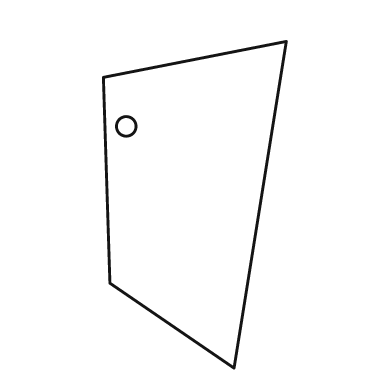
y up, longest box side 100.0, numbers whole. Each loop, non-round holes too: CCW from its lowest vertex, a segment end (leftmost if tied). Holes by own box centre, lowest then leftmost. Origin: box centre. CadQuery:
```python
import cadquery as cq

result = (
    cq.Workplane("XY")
    .moveTo(12.0, -50.0)
    .lineTo(28.0, 50.0)
    .lineTo(-28.0, 39.0)
    .lineTo(-26.0, -24.0)
    .close()
    .moveTo(-21.0, 24.0)
    .circle(3.0)
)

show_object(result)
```